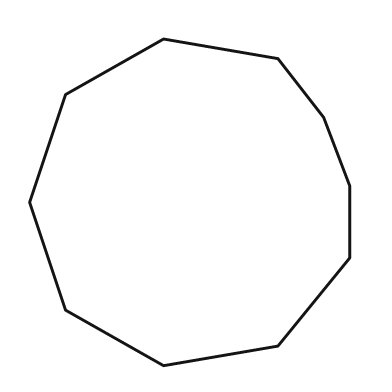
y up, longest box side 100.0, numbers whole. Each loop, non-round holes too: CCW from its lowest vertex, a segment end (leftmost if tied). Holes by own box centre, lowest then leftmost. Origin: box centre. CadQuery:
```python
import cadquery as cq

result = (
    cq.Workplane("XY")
    .moveTo(-8.0, -50.0)
    .lineTo(27.0, -44.0)
    .lineTo(49.0, -17.0)
    .lineTo(49.0, 5.0)
    .lineTo(41.0, 26.0)
    .lineTo(27.0, 44.0)
    .lineTo(-8.0, 50.0)
    .lineTo(-38.0, 33.0)
    .lineTo(-49.0, 0.0)
    .lineTo(-38.0, -33.0)
    .close()
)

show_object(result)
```